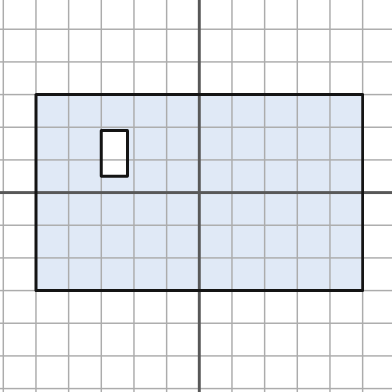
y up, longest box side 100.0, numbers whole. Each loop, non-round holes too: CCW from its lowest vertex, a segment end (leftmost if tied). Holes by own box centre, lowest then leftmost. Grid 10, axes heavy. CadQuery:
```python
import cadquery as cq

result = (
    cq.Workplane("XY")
    .moveTo(-50.0, -30.0)
    .lineTo(50.0, -30.0)
    .lineTo(50.0, 30.0)
    .lineTo(-50.0, 30.0)
    .close()
    .moveTo(-30.0, 5.0)
    .lineTo(-22.0, 5.0)
    .lineTo(-22.0, 19.0)
    .lineTo(-30.0, 19.0)
    .close()
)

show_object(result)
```